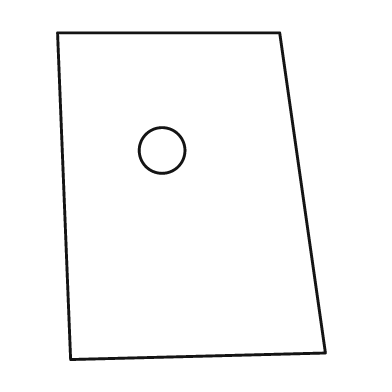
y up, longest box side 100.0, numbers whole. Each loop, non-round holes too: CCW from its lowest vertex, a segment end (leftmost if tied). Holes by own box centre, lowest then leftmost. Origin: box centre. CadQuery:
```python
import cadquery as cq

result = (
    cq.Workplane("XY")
    .moveTo(-37.0, -50.0)
    .lineTo(41.0, -48.0)
    .lineTo(27.0, 50.0)
    .lineTo(-41.0, 50.0)
    .close()
    .moveTo(-9.0, 14.0)
    .circle(7.0)
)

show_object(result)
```